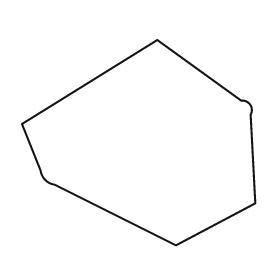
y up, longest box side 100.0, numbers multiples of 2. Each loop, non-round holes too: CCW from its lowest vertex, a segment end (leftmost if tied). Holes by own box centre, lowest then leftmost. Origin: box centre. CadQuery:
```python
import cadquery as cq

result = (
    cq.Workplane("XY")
    .moveTo(16.0, -44.0)
    .lineTo(50.0, -26.0)
    .lineTo(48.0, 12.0)
    .threePointArc((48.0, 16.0), (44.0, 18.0))
    .lineTo(8.0, 44.0)
    .lineTo(-50.0, 8.0)
    .lineTo(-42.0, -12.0)
    .threePointArc((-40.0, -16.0), (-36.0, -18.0))
    .close()
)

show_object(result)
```